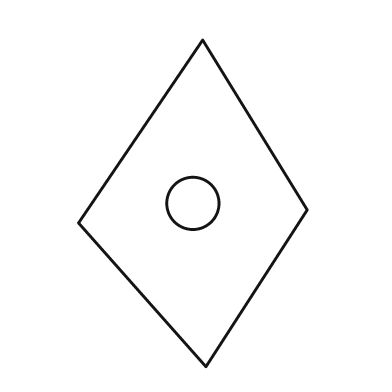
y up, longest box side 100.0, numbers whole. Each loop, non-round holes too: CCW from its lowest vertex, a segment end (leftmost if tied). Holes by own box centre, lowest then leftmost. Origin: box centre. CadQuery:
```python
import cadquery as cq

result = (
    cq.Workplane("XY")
    .moveTo(4.0, -50.0)
    .lineTo(35.0, -2.0)
    .lineTo(3.0, 50.0)
    .lineTo(-35.0, -6.0)
    .close()
    .moveTo(0.0, 0.0)
    .circle(8.0)
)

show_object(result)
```